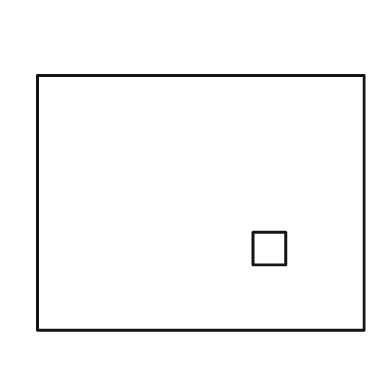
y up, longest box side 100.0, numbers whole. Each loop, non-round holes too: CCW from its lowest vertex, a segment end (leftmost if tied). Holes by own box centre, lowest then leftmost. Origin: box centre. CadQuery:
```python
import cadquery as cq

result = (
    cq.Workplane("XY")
    .moveTo(-50.0, -39.0)
    .lineTo(50.0, -39.0)
    .lineTo(50.0, 39.0)
    .lineTo(-50.0, 39.0)
    .close()
    .moveTo(16.0, -19.0)
    .lineTo(26.0, -19.0)
    .lineTo(26.0, -9.0)
    .lineTo(16.0, -9.0)
    .close()
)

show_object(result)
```